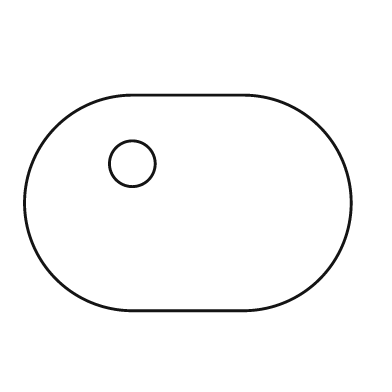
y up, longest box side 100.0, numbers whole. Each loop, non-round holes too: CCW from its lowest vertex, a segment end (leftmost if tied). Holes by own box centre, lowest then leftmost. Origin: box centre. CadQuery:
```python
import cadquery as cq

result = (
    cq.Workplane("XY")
    .moveTo(-17.0, -33.0)
    .lineTo(17.0, -33.0)
    .threePointArc((50.0, 0.0), (17.0, 33.0))
    .lineTo(-17.0, 33.0)
    .threePointArc((-50.0, 0.0), (-17.0, -33.0))
    .close()
    .moveTo(-17.0, 12.0)
    .circle(7.0)
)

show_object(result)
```